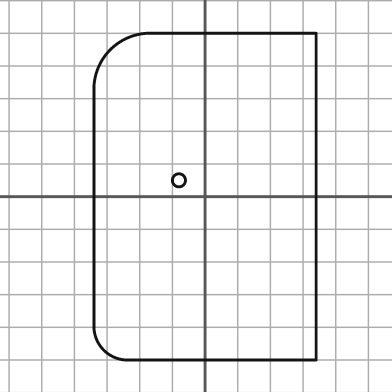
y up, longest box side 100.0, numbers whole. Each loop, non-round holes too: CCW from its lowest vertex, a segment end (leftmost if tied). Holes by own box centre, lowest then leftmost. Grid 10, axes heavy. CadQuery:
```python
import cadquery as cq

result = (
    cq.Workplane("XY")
    .moveTo(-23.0, -50.0)
    .lineTo(34.0, -50.0)
    .lineTo(34.0, 50.0)
    .lineTo(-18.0, 50.0)
    .threePointArc((-29.0, 45.0), (-34.0, 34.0))
    .lineTo(-34.0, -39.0)
    .threePointArc((-31.0, -47.0), (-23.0, -50.0))
    .close()
    .moveTo(-8.0, 5.0)
    .circle(2.0)
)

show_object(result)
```